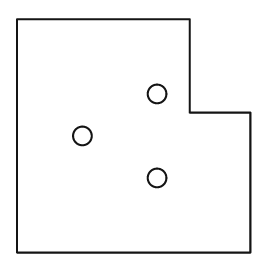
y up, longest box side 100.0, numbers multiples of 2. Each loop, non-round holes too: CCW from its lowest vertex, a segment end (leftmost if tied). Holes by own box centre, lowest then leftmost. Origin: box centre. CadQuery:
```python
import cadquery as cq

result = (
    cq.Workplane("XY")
    .moveTo(-50.0, -50.0)
    .lineTo(50.0, -50.0)
    .lineTo(50.0, 10.0)
    .lineTo(24.0, 10.0)
    .lineTo(24.0, 50.0)
    .lineTo(-50.0, 50.0)
    .close()
    .moveTo(10.0, -18.0)
    .circle(4.0)
    .moveTo(-22.0, 0.0)
    .circle(4.0)
    .moveTo(10.0, 18.0)
    .circle(4.0)
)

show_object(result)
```